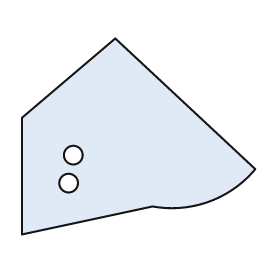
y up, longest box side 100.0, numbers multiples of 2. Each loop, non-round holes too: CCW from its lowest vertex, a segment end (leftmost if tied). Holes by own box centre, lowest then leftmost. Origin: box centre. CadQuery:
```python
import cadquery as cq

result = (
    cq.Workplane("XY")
    .moveTo(-50.0, -42.0)
    .lineTo(6.0, -30.0)
    .threePointArc((30.0, -28.0), (50.0, -14.0))
    .lineTo(-10.0, 42.0)
    .lineTo(-50.0, 8.0)
    .close()
    .moveTo(-30.0, -20.0)
    .circle(4.0)
    .moveTo(-28.0, -8.0)
    .circle(4.0)
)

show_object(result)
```